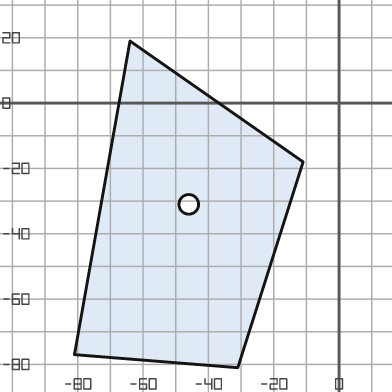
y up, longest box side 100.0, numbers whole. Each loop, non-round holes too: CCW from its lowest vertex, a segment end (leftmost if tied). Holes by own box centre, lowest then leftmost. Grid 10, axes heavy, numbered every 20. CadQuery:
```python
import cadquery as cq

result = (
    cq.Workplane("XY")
    .moveTo(-31.0, -81.0)
    .lineTo(-11.0, -18.0)
    .lineTo(-64.0, 19.0)
    .lineTo(-81.0, -77.0)
    .close()
    .moveTo(-46.0, -31.0)
    .circle(3.0)
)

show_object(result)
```